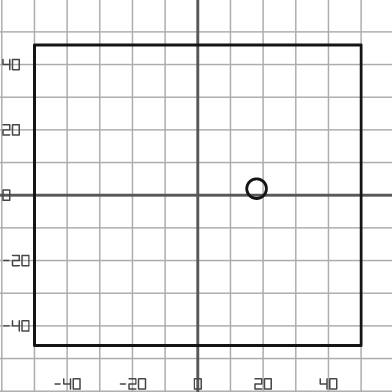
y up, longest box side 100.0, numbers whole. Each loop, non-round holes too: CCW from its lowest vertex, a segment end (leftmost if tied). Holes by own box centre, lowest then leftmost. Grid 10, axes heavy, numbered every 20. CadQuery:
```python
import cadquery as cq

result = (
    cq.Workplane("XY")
    .moveTo(-50.0, -46.0)
    .lineTo(50.0, -46.0)
    .lineTo(50.0, 46.0)
    .lineTo(-50.0, 46.0)
    .close()
    .moveTo(18.0, 2.0)
    .circle(3.0)
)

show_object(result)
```